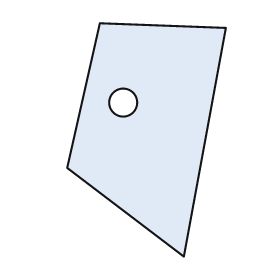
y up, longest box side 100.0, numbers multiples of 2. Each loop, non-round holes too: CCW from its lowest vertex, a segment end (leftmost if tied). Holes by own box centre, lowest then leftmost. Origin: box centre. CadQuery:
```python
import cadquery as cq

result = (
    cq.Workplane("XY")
    .moveTo(16.0, -50.0)
    .lineTo(34.0, 48.0)
    .lineTo(-20.0, 50.0)
    .lineTo(-34.0, -12.0)
    .close()
    .moveTo(-10.0, 16.0)
    .circle(6.0)
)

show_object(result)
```